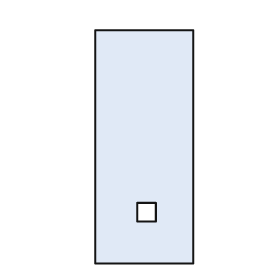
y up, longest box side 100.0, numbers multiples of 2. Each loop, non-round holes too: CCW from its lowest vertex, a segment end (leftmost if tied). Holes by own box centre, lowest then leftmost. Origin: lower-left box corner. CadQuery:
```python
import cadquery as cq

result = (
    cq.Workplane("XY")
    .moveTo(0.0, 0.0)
    .lineTo(42.0, 0.0)
    .lineTo(42.0, 100.0)
    .lineTo(0.0, 100.0)
    .close()
    .moveTo(18.0, 18.0)
    .lineTo(26.0, 18.0)
    .lineTo(26.0, 26.0)
    .lineTo(18.0, 26.0)
    .close()
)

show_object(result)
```